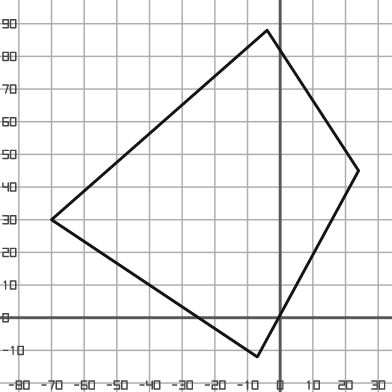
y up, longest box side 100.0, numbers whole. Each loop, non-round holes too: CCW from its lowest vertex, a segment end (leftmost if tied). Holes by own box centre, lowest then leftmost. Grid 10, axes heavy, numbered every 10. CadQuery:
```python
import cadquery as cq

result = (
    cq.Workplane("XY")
    .moveTo(-7.0, -12.0)
    .lineTo(24.0, 45.0)
    .lineTo(-4.0, 88.0)
    .lineTo(-70.0, 30.0)
    .close()
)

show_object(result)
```